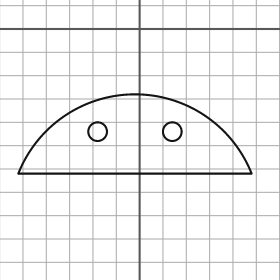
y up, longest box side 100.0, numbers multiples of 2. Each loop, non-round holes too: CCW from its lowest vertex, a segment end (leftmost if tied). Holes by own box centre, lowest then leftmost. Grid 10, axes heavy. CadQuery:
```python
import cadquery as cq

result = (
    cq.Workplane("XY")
    .moveTo(-52.0, -62.0)
    .lineTo(48.0, -62.0)
    .threePointArc((-2.0, -28.0), (-52.0, -62.0))
    .close()
    .moveTo(-18.0, -44.0)
    .circle(4.0)
    .moveTo(14.0, -44.0)
    .circle(4.0)
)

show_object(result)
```